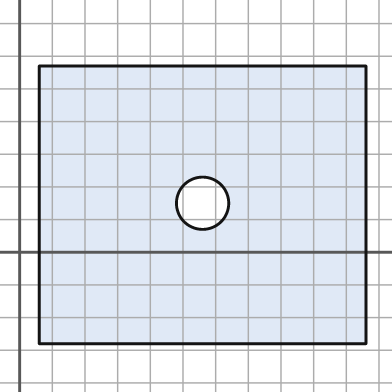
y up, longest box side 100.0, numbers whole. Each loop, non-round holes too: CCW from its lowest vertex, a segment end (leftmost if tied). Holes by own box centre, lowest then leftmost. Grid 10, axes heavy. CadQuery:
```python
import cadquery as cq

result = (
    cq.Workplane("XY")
    .moveTo(6.0, -28.0)
    .lineTo(106.0, -28.0)
    .lineTo(106.0, 57.0)
    .lineTo(6.0, 57.0)
    .close()
    .moveTo(56.0, 15.0)
    .circle(8.0)
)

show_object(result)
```